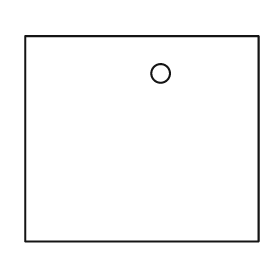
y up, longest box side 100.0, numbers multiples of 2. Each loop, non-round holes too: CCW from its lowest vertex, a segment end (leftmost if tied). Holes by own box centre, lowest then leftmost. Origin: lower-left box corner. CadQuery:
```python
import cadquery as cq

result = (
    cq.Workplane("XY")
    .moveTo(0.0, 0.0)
    .lineTo(100.0, 0.0)
    .lineTo(100.0, 88.0)
    .lineTo(0.0, 88.0)
    .close()
    .moveTo(58.0, 72.0)
    .circle(4.0)
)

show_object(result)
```